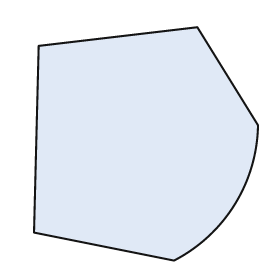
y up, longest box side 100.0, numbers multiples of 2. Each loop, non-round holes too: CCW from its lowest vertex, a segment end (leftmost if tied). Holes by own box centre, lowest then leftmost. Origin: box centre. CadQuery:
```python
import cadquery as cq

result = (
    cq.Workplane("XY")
    .moveTo(12.0, -50.0)
    .threePointArc((38.0, -26.0), (48.0, 8.0))
    .lineTo(22.0, 50.0)
    .lineTo(-46.0, 42.0)
    .lineTo(-48.0, -38.0)
    .close()
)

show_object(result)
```